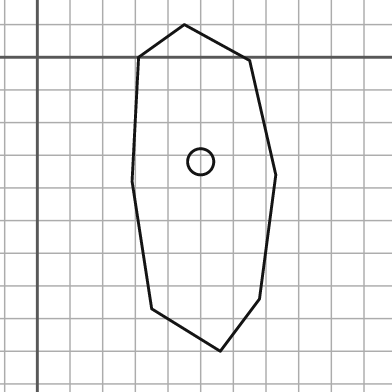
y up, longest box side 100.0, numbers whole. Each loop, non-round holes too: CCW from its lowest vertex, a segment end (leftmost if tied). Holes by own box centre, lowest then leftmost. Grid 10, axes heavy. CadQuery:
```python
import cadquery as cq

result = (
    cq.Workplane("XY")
    .moveTo(56.0, -90.0)
    .lineTo(68.0, -74.0)
    .lineTo(73.0, -36.0)
    .lineTo(65.0, -1.0)
    .lineTo(45.0, 10.0)
    .lineTo(31.0, 0.0)
    .lineTo(29.0, -38.0)
    .lineTo(35.0, -77.0)
    .close()
    .moveTo(50.0, -32.0)
    .circle(4.0)
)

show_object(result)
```